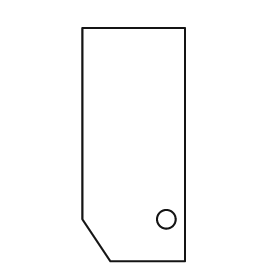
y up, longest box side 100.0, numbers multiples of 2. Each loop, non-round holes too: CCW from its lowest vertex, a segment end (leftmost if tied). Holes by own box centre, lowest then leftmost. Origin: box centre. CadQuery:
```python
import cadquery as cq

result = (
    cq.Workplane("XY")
    .moveTo(-10.0, -50.0)
    .lineTo(22.0, -50.0)
    .lineTo(22.0, 50.0)
    .lineTo(-22.0, 50.0)
    .lineTo(-22.0, -32.0)
    .close()
    .moveTo(14.0, -32.0)
    .circle(4.0)
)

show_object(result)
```